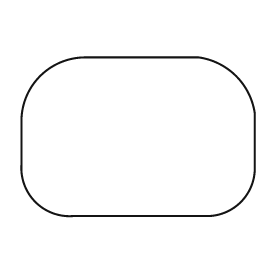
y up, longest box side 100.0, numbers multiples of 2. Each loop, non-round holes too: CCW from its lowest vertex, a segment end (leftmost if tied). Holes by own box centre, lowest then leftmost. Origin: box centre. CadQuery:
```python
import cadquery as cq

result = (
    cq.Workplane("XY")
    .moveTo(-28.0, -34.0)
    .lineTo(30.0, -34.0)
    .threePointArc((44.0, -28.0), (50.0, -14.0))
    .lineTo(50.0, 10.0)
    .threePointArc((42.0, 26.0), (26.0, 34.0))
    .lineTo(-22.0, 34.0)
    .threePointArc((-42.0, 26.0), (-50.0, 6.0))
    .lineTo(-50.0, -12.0)
    .threePointArc((-44.0, -28.0), (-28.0, -34.0))
    .close()
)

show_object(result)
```